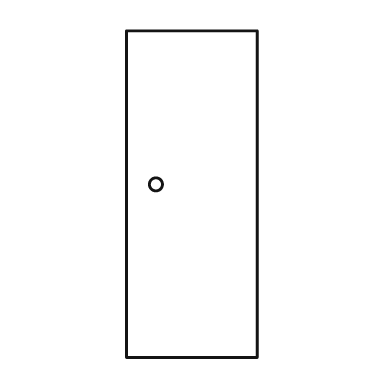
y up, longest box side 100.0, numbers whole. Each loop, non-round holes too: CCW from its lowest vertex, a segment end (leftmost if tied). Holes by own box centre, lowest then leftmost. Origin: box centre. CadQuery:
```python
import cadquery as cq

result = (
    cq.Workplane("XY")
    .moveTo(-20.0, -50.0)
    .lineTo(20.0, -50.0)
    .lineTo(20.0, 50.0)
    .lineTo(-20.0, 50.0)
    .close()
    .moveTo(-11.0, 3.0)
    .circle(2.0)
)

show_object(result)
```